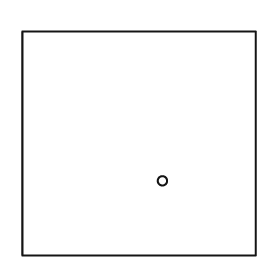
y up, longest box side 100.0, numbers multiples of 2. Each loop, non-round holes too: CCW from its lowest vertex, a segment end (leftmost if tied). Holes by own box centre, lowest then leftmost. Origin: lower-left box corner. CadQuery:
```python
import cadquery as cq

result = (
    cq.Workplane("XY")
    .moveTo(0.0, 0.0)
    .lineTo(100.0, 0.0)
    .lineTo(100.0, 96.0)
    .lineTo(0.0, 96.0)
    .close()
    .moveTo(60.0, 32.0)
    .circle(2.0)
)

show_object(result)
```